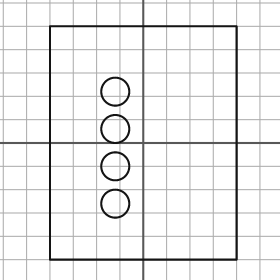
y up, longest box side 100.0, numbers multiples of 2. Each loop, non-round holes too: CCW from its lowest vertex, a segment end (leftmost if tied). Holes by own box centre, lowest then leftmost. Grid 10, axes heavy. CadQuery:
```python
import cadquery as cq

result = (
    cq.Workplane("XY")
    .moveTo(-40.0, -50.0)
    .lineTo(40.0, -50.0)
    .lineTo(40.0, 50.0)
    .lineTo(-40.0, 50.0)
    .close()
    .moveTo(-12.0, -26.0)
    .circle(6.0)
    .moveTo(-12.0, -10.0)
    .circle(6.0)
    .moveTo(-12.0, 6.0)
    .circle(6.0)
    .moveTo(-12.0, 22.0)
    .circle(6.0)
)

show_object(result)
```